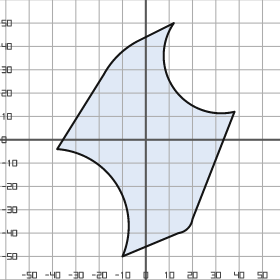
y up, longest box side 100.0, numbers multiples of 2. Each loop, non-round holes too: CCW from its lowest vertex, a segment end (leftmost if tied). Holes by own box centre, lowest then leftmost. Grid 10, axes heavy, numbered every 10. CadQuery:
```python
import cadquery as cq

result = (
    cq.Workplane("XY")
    .moveTo(-10.0, -50.0)
    .lineTo(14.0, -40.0)
    .threePointArc((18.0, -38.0), (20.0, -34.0))
    .lineTo(38.0, 12.0)
    .threePointArc((12.0, 22.0), (12.0, 50.0))
    .lineTo(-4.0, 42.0)
    .threePointArc((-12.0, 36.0), (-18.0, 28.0))
    .lineTo(-38.0, -4.0)
    .threePointArc((-12.0, -20.0), (-10.0, -50.0))
    .close()
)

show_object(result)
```